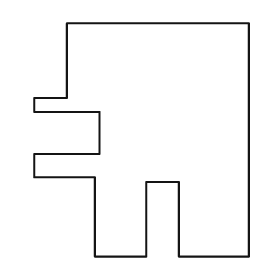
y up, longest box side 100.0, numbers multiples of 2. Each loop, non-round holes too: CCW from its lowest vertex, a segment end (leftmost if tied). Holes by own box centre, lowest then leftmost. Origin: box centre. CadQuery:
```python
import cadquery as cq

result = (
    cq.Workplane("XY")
    .moveTo(-20.0, -50.0)
    .lineTo(2.0, -50.0)
    .lineTo(2.0, -18.0)
    .lineTo(16.0, -18.0)
    .lineTo(16.0, -50.0)
    .lineTo(46.0, -50.0)
    .lineTo(46.0, 50.0)
    .lineTo(-32.0, 50.0)
    .lineTo(-32.0, 18.0)
    .lineTo(-46.0, 18.0)
    .lineTo(-46.0, 12.0)
    .lineTo(-18.0, 12.0)
    .lineTo(-18.0, -6.0)
    .lineTo(-46.0, -6.0)
    .lineTo(-46.0, -16.0)
    .lineTo(-20.0, -16.0)
    .close()
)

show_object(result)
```